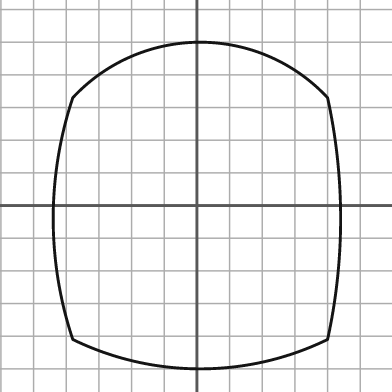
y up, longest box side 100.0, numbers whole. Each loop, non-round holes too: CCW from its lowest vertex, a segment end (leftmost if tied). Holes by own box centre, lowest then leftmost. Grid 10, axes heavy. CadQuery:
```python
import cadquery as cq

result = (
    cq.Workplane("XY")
    .moveTo(-38.0, -41.0)
    .threePointArc((1.0, -50.0), (40.0, -41.0))
    .threePointArc((44.0, -4.0), (40.0, 33.0))
    .threePointArc((1.0, 50.0), (-38.0, 33.0))
    .threePointArc((-44.0, -4.0), (-38.0, -41.0))
    .close()
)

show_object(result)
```